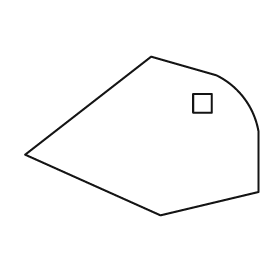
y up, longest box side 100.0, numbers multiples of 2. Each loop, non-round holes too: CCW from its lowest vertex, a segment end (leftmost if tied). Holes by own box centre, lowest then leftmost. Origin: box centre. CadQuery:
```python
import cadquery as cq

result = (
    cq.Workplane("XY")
    .moveTo(8.0, -34.0)
    .lineTo(50.0, -24.0)
    .lineTo(50.0, 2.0)
    .threePointArc((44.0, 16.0), (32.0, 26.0))
    .lineTo(4.0, 34.0)
    .lineTo(-50.0, -8.0)
    .close()
    .moveTo(22.0, 10.0)
    .lineTo(30.0, 10.0)
    .lineTo(30.0, 18.0)
    .lineTo(22.0, 18.0)
    .close()
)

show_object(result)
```